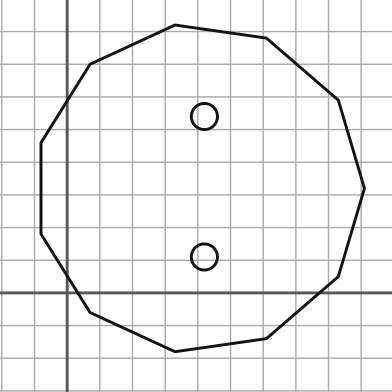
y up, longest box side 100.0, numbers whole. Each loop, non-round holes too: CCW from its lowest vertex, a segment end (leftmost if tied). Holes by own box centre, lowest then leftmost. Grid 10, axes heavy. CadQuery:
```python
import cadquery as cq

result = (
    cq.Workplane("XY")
    .moveTo(33.0, -18.0)
    .lineTo(61.0, -14.0)
    .lineTo(83.0, 5.0)
    .lineTo(91.0, 32.0)
    .lineTo(83.0, 59.0)
    .lineTo(61.0, 78.0)
    .lineTo(33.0, 82.0)
    .lineTo(7.0, 70.0)
    .lineTo(-8.0, 46.0)
    .lineTo(-8.0, 18.0)
    .lineTo(7.0, -6.0)
    .close()
    .moveTo(42.0, 11.0)
    .circle(4.0)
    .moveTo(42.0, 54.0)
    .circle(4.0)
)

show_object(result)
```